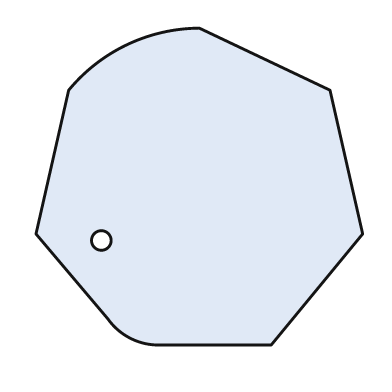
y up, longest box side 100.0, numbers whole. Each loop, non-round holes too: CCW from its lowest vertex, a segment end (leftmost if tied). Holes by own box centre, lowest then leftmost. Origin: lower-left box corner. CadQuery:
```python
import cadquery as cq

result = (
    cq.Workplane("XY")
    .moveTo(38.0, 0.0)
    .lineTo(72.0, 0.0)
    .lineTo(100.0, 34.0)
    .lineTo(90.0, 78.0)
    .lineTo(50.0, 97.0)
    .threePointArc((28.0, 92.0), (10.0, 78.0))
    .lineTo(0.0, 34.0)
    .lineTo(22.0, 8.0)
    .threePointArc((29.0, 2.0), (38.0, 0.0))
    .close()
    .moveTo(20.0, 32.0)
    .circle(3.0)
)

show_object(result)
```